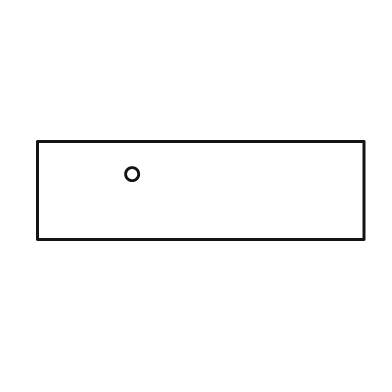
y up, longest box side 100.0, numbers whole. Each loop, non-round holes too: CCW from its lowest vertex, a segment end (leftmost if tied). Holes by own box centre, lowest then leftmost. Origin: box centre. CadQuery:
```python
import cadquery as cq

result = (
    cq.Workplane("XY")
    .moveTo(-50.0, -15.0)
    .lineTo(50.0, -15.0)
    .lineTo(50.0, 15.0)
    .lineTo(-50.0, 15.0)
    .close()
    .moveTo(-21.0, 5.0)
    .circle(2.0)
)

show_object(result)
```